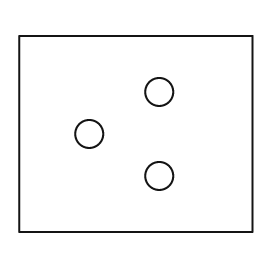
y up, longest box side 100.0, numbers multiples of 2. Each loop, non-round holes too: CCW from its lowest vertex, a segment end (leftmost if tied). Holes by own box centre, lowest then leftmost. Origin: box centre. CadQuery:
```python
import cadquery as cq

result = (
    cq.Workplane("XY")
    .moveTo(-50.0, -42.0)
    .lineTo(50.0, -42.0)
    .lineTo(50.0, 42.0)
    .lineTo(-50.0, 42.0)
    .close()
    .moveTo(10.0, -18.0)
    .circle(6.0)
    .moveTo(-20.0, 0.0)
    .circle(6.0)
    .moveTo(10.0, 18.0)
    .circle(6.0)
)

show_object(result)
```